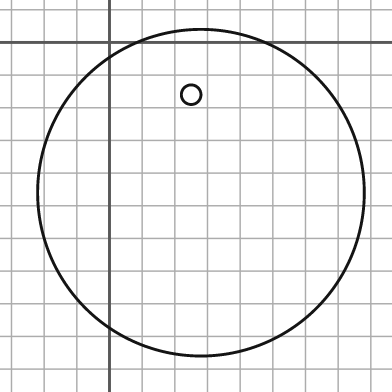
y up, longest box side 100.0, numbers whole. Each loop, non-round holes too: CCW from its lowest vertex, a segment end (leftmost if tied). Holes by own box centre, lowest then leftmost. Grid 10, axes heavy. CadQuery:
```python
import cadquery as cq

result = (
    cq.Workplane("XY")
    .moveTo(28.0, -46.0)
    .circle(50.0)
    .moveTo(25.0, -16.0)
    .circle(3.0)
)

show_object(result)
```